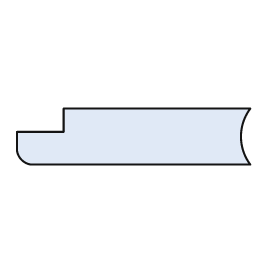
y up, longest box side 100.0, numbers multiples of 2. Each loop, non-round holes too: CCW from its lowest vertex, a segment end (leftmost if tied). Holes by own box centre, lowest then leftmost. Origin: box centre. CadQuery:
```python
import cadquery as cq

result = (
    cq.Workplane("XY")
    .moveTo(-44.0, -12.0)
    .lineTo(50.0, -12.0)
    .threePointArc((46.0, 0.0), (50.0, 12.0))
    .lineTo(-30.0, 12.0)
    .lineTo(-30.0, 2.0)
    .lineTo(-50.0, 2.0)
    .lineTo(-50.0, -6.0)
    .threePointArc((-48.0, -10.0), (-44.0, -12.0))
    .close()
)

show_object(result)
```